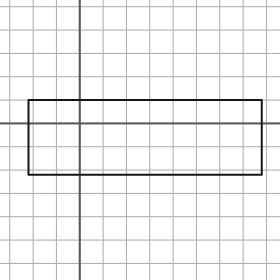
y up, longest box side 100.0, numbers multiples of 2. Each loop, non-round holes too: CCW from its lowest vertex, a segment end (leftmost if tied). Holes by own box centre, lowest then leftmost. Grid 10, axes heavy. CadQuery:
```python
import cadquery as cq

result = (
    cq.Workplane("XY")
    .moveTo(-22.0, -22.0)
    .lineTo(78.0, -22.0)
    .lineTo(78.0, 10.0)
    .lineTo(-22.0, 10.0)
    .close()
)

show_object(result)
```